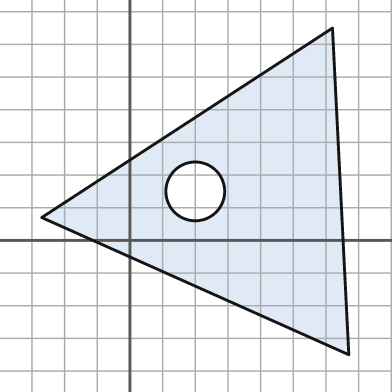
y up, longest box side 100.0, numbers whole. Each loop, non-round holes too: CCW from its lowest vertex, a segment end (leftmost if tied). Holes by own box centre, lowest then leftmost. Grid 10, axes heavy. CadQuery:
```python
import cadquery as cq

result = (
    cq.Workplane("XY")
    .moveTo(67.0, -35.0)
    .lineTo(62.0, 65.0)
    .lineTo(-27.0, 7.0)
    .close()
    .moveTo(20.0, 15.0)
    .circle(9.0)
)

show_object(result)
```